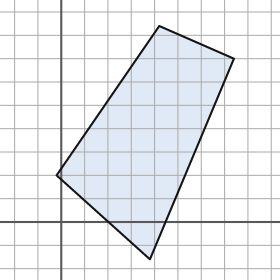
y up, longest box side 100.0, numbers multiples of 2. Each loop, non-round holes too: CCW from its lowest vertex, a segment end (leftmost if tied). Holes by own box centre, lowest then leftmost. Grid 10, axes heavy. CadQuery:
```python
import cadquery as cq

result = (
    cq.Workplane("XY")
    .moveTo(38.0, -16.0)
    .lineTo(74.0, 70.0)
    .lineTo(42.0, 84.0)
    .lineTo(-2.0, 20.0)
    .close()
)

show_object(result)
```